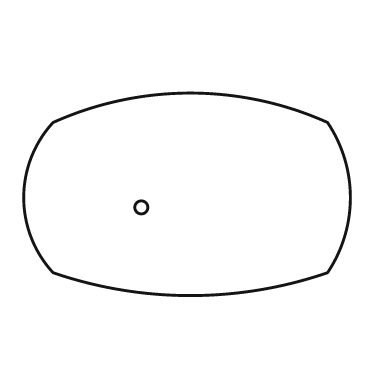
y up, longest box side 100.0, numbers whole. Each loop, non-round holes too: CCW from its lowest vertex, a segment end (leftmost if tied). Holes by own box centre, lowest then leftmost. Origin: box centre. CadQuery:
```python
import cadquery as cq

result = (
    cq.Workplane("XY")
    .moveTo(-41.0, -24.0)
    .threePointArc((1.0, -31.0), (43.0, -24.0))
    .threePointArc((50.0, -1.0), (43.0, 22.0))
    .threePointArc((1.0, 31.0), (-41.0, 22.0))
    .threePointArc((-50.0, -1.0), (-41.0, -24.0))
    .close()
    .moveTo(-14.0, -4.0)
    .circle(2.0)
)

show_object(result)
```